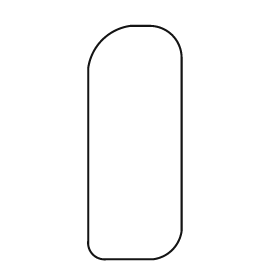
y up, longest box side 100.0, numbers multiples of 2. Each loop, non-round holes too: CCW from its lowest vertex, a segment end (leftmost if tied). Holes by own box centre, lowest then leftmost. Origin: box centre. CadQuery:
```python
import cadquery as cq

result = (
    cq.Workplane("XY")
    .moveTo(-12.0, -50.0)
    .lineTo(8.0, -50.0)
    .threePointArc((16.0, -46.0), (20.0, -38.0))
    .lineTo(20.0, 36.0)
    .threePointArc((16.0, 46.0), (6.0, 50.0))
    .lineTo(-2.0, 50.0)
    .threePointArc((-14.0, 44.0), (-20.0, 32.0))
    .lineTo(-20.0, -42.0)
    .threePointArc((-18.0, -48.0), (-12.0, -50.0))
    .close()
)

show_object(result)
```